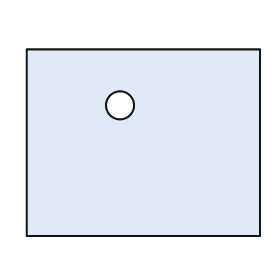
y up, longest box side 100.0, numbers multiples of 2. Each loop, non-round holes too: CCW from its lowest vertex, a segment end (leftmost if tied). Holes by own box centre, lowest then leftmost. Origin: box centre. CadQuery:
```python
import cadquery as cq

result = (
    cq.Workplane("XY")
    .moveTo(-50.0, -40.0)
    .lineTo(50.0, -40.0)
    .lineTo(50.0, 40.0)
    .lineTo(-50.0, 40.0)
    .close()
    .moveTo(-10.0, 16.0)
    .circle(6.0)
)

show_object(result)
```